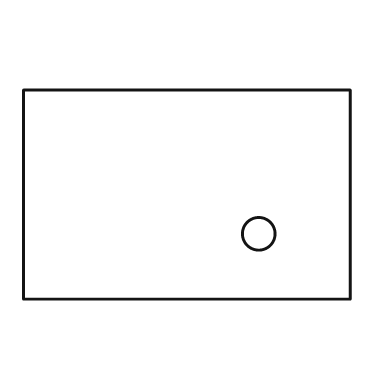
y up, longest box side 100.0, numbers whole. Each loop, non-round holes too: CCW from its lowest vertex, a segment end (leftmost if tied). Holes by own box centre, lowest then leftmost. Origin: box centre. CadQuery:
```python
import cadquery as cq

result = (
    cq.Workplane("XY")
    .moveTo(-50.0, -32.0)
    .lineTo(50.0, -32.0)
    .lineTo(50.0, 32.0)
    .lineTo(-50.0, 32.0)
    .close()
    .moveTo(22.0, -12.0)
    .circle(5.0)
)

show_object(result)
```